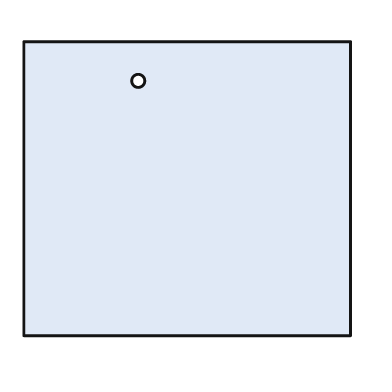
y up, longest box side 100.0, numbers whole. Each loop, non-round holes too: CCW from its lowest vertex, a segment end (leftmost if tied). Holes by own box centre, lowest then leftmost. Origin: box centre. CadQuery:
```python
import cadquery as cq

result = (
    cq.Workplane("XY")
    .moveTo(-50.0, -45.0)
    .lineTo(50.0, -45.0)
    .lineTo(50.0, 45.0)
    .lineTo(-50.0, 45.0)
    .close()
    .moveTo(-15.0, 33.0)
    .circle(2.0)
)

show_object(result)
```